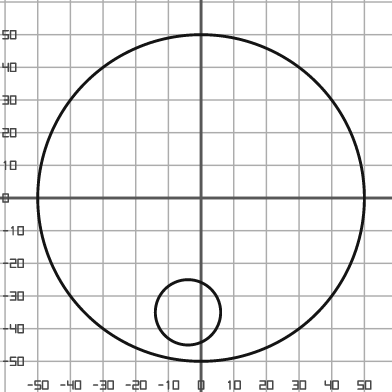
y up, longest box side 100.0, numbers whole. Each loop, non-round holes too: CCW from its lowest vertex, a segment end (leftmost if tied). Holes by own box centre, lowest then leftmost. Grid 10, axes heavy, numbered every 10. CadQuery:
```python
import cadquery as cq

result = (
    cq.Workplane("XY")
    .moveTo(0.0, 0.0)
    .circle(50.0)
    .moveTo(-4.0, -35.0)
    .circle(10.0)
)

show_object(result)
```